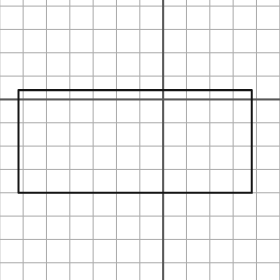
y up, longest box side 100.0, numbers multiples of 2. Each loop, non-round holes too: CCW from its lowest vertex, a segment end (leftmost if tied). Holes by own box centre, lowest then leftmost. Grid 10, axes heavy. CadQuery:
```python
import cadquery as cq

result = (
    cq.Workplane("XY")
    .moveTo(-62.0, -40.0)
    .lineTo(38.0, -40.0)
    .lineTo(38.0, 4.0)
    .lineTo(-62.0, 4.0)
    .close()
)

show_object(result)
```